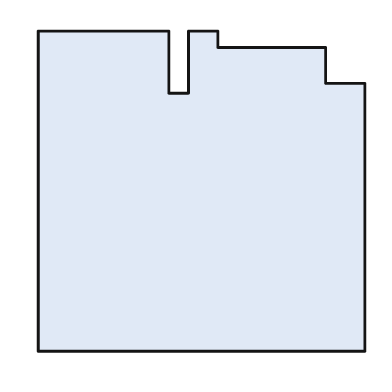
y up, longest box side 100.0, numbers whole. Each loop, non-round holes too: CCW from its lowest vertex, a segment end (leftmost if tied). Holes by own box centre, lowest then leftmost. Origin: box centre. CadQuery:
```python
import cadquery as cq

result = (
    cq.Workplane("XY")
    .moveTo(-50.0, -49.0)
    .lineTo(50.0, -49.0)
    .lineTo(50.0, 33.0)
    .lineTo(38.0, 33.0)
    .lineTo(38.0, 44.0)
    .lineTo(5.0, 44.0)
    .lineTo(5.0, 49.0)
    .lineTo(-4.0, 49.0)
    .lineTo(-4.0, 30.0)
    .lineTo(-10.0, 30.0)
    .lineTo(-10.0, 49.0)
    .lineTo(-50.0, 49.0)
    .close()
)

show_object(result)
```